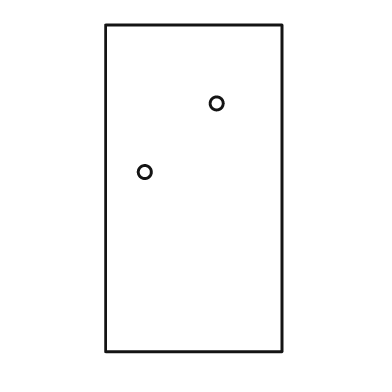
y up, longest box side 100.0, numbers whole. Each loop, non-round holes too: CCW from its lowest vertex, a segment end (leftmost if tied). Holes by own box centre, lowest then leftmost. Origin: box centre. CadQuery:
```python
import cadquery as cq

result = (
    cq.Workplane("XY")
    .moveTo(-27.0, -50.0)
    .lineTo(27.0, -50.0)
    .lineTo(27.0, 50.0)
    .lineTo(-27.0, 50.0)
    .close()
    .moveTo(-15.0, 5.0)
    .circle(2.0)
    .moveTo(7.0, 26.0)
    .circle(2.0)
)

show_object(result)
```